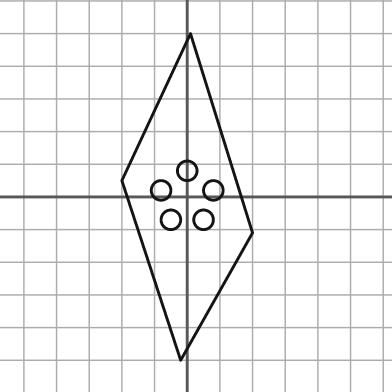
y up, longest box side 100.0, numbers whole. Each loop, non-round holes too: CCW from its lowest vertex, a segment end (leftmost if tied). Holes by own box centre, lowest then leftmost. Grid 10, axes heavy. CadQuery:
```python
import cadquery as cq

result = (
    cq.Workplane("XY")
    .moveTo(-2.0, -50.0)
    .lineTo(20.0, -11.0)
    .lineTo(1.0, 50.0)
    .lineTo(-20.0, 5.0)
    .close()
    .moveTo(-5.0, -7.0)
    .circle(3.0)
    .moveTo(5.0, -7.0)
    .circle(3.0)
    .moveTo(-8.0, 2.0)
    .circle(3.0)
    .moveTo(8.0, 2.0)
    .circle(3.0)
    .moveTo(0.0, 8.0)
    .circle(3.0)
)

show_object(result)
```